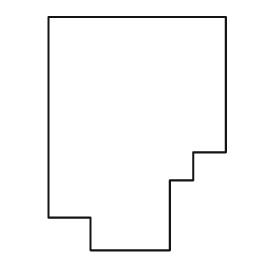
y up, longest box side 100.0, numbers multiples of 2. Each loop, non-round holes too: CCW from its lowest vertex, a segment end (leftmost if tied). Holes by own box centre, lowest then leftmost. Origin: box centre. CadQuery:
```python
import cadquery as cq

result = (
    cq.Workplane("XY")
    .moveTo(-20.0, -50.0)
    .lineTo(14.0, -50.0)
    .lineTo(14.0, -20.0)
    .lineTo(24.0, -20.0)
    .lineTo(24.0, -8.0)
    .lineTo(38.0, -8.0)
    .lineTo(38.0, 50.0)
    .lineTo(-38.0, 50.0)
    .lineTo(-38.0, -36.0)
    .lineTo(-20.0, -36.0)
    .close()
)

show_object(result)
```